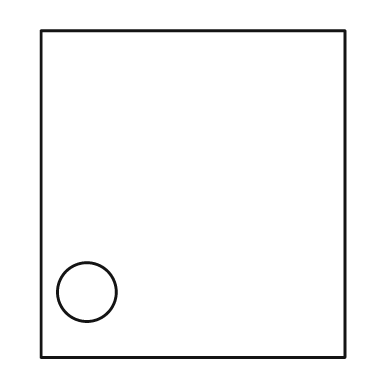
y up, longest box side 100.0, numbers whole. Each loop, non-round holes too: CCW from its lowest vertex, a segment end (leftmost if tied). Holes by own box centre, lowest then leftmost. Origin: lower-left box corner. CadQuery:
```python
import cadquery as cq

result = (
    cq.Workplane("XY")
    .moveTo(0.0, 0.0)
    .lineTo(93.0, 0.0)
    .lineTo(93.0, 100.0)
    .lineTo(0.0, 100.0)
    .close()
    .moveTo(14.0, 20.0)
    .circle(9.0)
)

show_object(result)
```